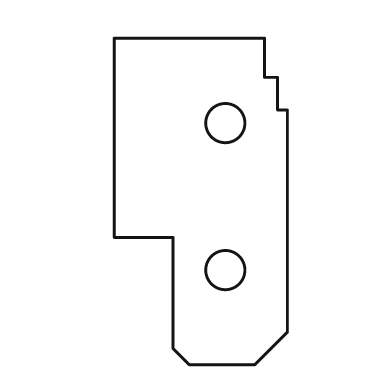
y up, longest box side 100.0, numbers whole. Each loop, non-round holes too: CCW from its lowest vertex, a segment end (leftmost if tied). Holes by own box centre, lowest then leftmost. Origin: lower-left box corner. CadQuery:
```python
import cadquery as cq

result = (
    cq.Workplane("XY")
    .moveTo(23.0, 0.0)
    .lineTo(43.0, 0.0)
    .lineTo(53.0, 10.0)
    .lineTo(53.0, 78.0)
    .lineTo(50.0, 78.0)
    .lineTo(50.0, 88.0)
    .lineTo(46.0, 88.0)
    .lineTo(46.0, 100.0)
    .lineTo(0.0, 100.0)
    .lineTo(0.0, 39.0)
    .lineTo(18.0, 39.0)
    .lineTo(18.0, 5.0)
    .close()
    .moveTo(34.0, 29.0)
    .circle(6.0)
    .moveTo(34.0, 74.0)
    .circle(6.0)
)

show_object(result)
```